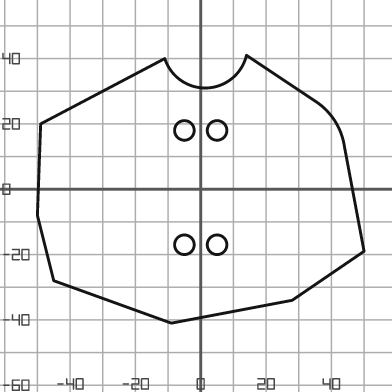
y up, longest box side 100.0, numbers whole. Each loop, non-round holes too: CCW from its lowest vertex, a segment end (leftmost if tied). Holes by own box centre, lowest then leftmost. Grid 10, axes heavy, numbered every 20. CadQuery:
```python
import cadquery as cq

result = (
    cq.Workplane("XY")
    .moveTo(-9.0, -41.0)
    .lineTo(28.0, -34.0)
    .lineTo(50.0, -19.0)
    .lineTo(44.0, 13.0)
    .threePointArc((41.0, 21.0), (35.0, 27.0))
    .lineTo(14.0, 41.0)
    .threePointArc((2.0, 31.0), (-11.0, 40.0))
    .lineTo(-49.0, 20.0)
    .lineTo(-50.0, -8.0)
    .lineTo(-45.0, -28.0)
    .close()
    .moveTo(-5.0, -17.0)
    .circle(3.0)
    .moveTo(5.0, -17.0)
    .circle(3.0)
    .moveTo(-5.0, 18.0)
    .circle(3.0)
    .moveTo(5.0, 18.0)
    .circle(3.0)
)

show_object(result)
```